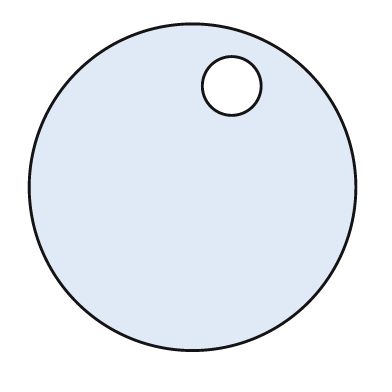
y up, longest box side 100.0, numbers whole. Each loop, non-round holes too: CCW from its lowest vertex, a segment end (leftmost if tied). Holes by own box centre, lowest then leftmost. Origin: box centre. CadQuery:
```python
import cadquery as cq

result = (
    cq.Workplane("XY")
    .moveTo(0.0, 0.0)
    .circle(50.0)
    .moveTo(12.0, 31.0)
    .circle(9.0)
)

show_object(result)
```